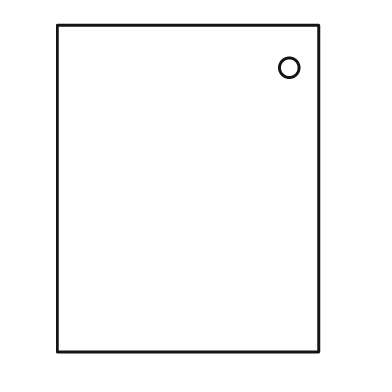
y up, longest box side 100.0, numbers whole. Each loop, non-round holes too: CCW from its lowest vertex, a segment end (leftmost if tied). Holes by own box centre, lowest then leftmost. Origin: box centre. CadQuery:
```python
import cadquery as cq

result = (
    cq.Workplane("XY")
    .moveTo(-40.0, -50.0)
    .lineTo(40.0, -50.0)
    .lineTo(40.0, 50.0)
    .lineTo(-40.0, 50.0)
    .close()
    .moveTo(31.0, 37.0)
    .circle(3.0)
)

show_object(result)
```